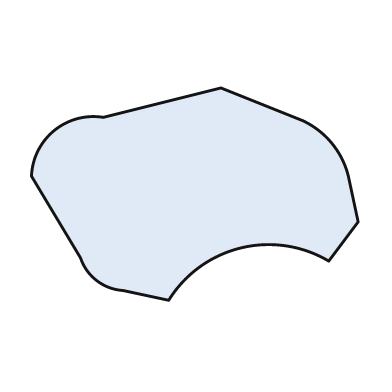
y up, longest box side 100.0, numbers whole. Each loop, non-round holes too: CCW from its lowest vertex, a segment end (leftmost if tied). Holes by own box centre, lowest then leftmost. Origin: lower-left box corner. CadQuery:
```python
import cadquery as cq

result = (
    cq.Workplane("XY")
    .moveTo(42.0, 0.0)
    .threePointArc((64.0, 16.0), (91.0, 12.0))
    .lineTo(100.0, 24.0)
    .lineTo(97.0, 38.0)
    .threePointArc((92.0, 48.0), (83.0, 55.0))
    .lineTo(58.0, 65.0)
    .lineTo(22.0, 56.0)
    .threePointArc((7.0, 52.0), (0.0, 38.0))
    .lineTo(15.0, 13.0)
    .threePointArc((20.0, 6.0), (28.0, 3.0))
    .close()
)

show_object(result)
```